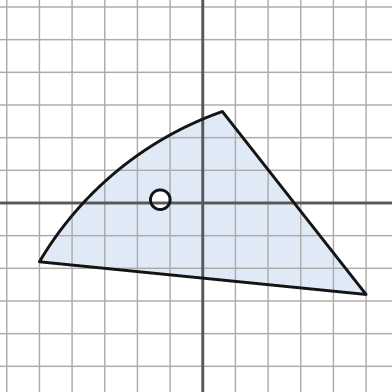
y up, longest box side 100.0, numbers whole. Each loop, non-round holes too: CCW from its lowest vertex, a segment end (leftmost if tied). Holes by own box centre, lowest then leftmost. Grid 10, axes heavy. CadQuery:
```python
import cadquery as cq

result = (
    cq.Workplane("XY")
    .moveTo(50.0, -28.0)
    .lineTo(6.0, 28.0)
    .threePointArc((-26.0, 10.0), (-50.0, -18.0))
    .close()
    .moveTo(-13.0, 1.0)
    .circle(3.0)
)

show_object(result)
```